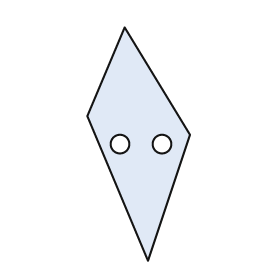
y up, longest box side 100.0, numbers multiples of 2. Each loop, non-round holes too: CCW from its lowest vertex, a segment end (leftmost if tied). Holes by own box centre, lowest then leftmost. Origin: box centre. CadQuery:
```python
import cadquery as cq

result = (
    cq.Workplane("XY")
    .moveTo(4.0, -50.0)
    .lineTo(22.0, 4.0)
    .lineTo(-6.0, 50.0)
    .lineTo(-22.0, 12.0)
    .close()
    .moveTo(-8.0, 0.0)
    .circle(4.0)
    .moveTo(10.0, 0.0)
    .circle(4.0)
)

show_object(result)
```